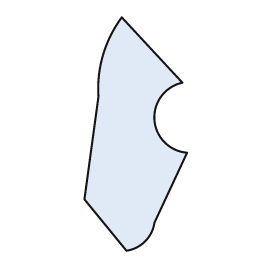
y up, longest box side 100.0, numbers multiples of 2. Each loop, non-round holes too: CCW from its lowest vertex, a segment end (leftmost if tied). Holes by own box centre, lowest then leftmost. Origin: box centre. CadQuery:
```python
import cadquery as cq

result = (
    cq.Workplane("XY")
    .moveTo(-4.0, -50.0)
    .threePointArc((4.0, -46.0), (8.0, -38.0))
    .lineTo(22.0, -8.0)
    .threePointArc((8.0, 6.0), (20.0, 22.0))
    .lineTo(-6.0, 50.0)
    .threePointArc((-14.0, 34.0), (-16.0, 16.0))
    .lineTo(-22.0, -28.0)
    .close()
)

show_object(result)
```